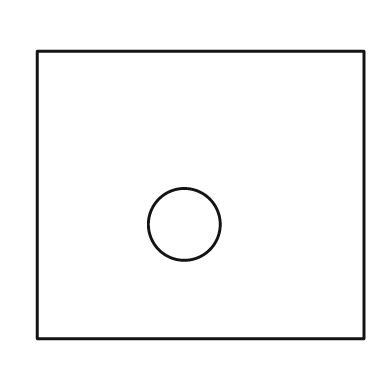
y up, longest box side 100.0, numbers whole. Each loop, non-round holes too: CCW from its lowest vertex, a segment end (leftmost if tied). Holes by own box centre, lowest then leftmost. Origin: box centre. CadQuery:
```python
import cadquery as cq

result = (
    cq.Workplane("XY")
    .moveTo(-50.0, -44.0)
    .lineTo(50.0, -44.0)
    .lineTo(50.0, 44.0)
    .lineTo(-50.0, 44.0)
    .close()
    .moveTo(-5.0, -9.0)
    .circle(11.0)
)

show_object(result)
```